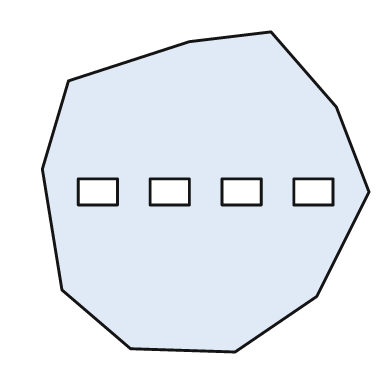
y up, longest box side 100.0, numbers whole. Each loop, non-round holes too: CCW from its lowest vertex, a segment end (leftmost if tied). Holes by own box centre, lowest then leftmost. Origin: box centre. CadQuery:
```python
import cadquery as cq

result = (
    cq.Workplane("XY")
    .moveTo(9.0, -49.0)
    .lineTo(34.0, -32.0)
    .lineTo(50.0, 0.0)
    .lineTo(40.0, 26.0)
    .lineTo(20.0, 49.0)
    .lineTo(-5.0, 46.0)
    .lineTo(-42.0, 34.0)
    .lineTo(-50.0, 7.0)
    .lineTo(-44.0, -30.0)
    .lineTo(-23.0, -48.0)
    .close()
    .moveTo(-39.0, -4.0)
    .lineTo(-27.0, -4.0)
    .lineTo(-27.0, 4.0)
    .lineTo(-39.0, 4.0)
    .close()
    .moveTo(-17.0, -4.0)
    .lineTo(-5.0, -4.0)
    .lineTo(-5.0, 4.0)
    .lineTo(-17.0, 4.0)
    .close()
    .moveTo(5.0, -4.0)
    .lineTo(17.0, -4.0)
    .lineTo(17.0, 4.0)
    .lineTo(5.0, 4.0)
    .close()
    .moveTo(27.0, -4.0)
    .lineTo(39.0, -4.0)
    .lineTo(39.0, 4.0)
    .lineTo(27.0, 4.0)
    .close()
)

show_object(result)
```